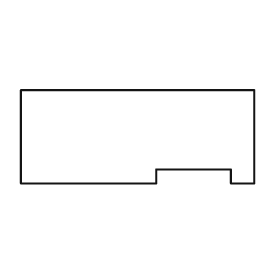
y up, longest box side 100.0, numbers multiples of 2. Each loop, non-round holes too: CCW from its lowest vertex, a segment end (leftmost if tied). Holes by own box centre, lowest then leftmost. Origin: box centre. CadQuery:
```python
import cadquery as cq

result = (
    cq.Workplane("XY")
    .moveTo(-50.0, -20.0)
    .lineTo(8.0, -20.0)
    .lineTo(8.0, -14.0)
    .lineTo(40.0, -14.0)
    .lineTo(40.0, -20.0)
    .lineTo(50.0, -20.0)
    .lineTo(50.0, 20.0)
    .lineTo(-50.0, 20.0)
    .close()
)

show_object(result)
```